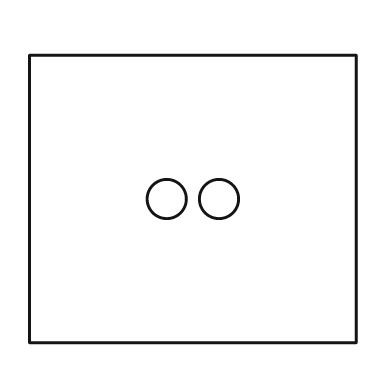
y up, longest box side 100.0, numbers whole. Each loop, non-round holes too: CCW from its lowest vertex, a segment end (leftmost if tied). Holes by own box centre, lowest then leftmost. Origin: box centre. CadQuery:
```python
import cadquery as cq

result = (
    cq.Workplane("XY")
    .moveTo(-50.0, -44.0)
    .lineTo(50.0, -44.0)
    .lineTo(50.0, 44.0)
    .lineTo(-50.0, 44.0)
    .close()
    .moveTo(-8.0, 0.0)
    .circle(6.0)
    .moveTo(8.0, 0.0)
    .circle(6.0)
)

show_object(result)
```